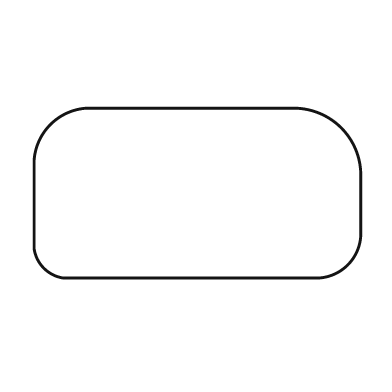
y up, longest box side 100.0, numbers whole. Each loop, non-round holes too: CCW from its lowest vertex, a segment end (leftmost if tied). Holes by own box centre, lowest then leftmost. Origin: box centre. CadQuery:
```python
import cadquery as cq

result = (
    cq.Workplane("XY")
    .moveTo(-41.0, -26.0)
    .lineTo(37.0, -26.0)
    .threePointArc((46.0, -22.0), (50.0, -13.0))
    .lineTo(50.0, 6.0)
    .threePointArc((44.0, 20.0), (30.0, 26.0))
    .lineTo(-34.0, 26.0)
    .threePointArc((-45.0, 21.0), (-50.0, 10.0))
    .lineTo(-50.0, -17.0)
    .threePointArc((-47.0, -23.0), (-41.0, -26.0))
    .close()
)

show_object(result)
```